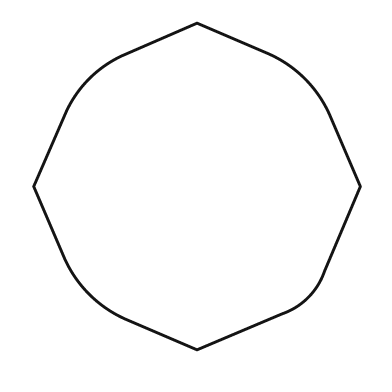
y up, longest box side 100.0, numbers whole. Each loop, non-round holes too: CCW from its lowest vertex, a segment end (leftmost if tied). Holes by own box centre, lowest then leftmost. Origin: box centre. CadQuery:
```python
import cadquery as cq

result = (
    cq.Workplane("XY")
    .moveTo(0.0, -50.0)
    .lineTo(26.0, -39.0)
    .threePointArc((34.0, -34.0), (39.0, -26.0))
    .lineTo(50.0, 0.0)
    .lineTo(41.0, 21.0)
    .threePointArc((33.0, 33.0), (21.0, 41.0))
    .lineTo(0.0, 50.0)
    .lineTo(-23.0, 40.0)
    .threePointArc((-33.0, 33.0), (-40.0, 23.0))
    .lineTo(-50.0, 0.0)
    .lineTo(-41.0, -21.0)
    .threePointArc((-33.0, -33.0), (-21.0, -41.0))
    .close()
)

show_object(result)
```